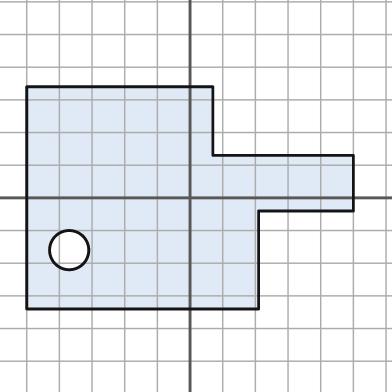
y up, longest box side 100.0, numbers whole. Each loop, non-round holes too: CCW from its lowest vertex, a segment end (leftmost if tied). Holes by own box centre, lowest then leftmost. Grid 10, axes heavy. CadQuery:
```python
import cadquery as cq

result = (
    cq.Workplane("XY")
    .moveTo(-50.0, -34.0)
    .lineTo(21.0, -34.0)
    .lineTo(21.0, -4.0)
    .lineTo(50.0, -4.0)
    .lineTo(50.0, 13.0)
    .lineTo(7.0, 13.0)
    .lineTo(7.0, 34.0)
    .lineTo(-50.0, 34.0)
    .close()
    .moveTo(-37.0, -16.0)
    .circle(6.0)
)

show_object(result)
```